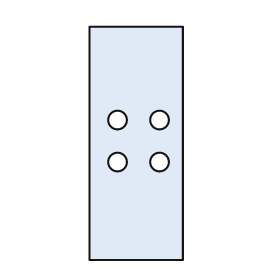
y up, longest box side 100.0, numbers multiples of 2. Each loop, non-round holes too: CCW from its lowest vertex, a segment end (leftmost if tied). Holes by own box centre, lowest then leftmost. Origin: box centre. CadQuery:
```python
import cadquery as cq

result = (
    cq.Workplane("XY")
    .moveTo(-20.0, -50.0)
    .lineTo(20.0, -50.0)
    .lineTo(20.0, 50.0)
    .lineTo(-20.0, 50.0)
    .close()
    .moveTo(-8.0, -8.0)
    .circle(4.0)
    .moveTo(10.0, -8.0)
    .circle(4.0)
    .moveTo(-8.0, 10.0)
    .circle(4.0)
    .moveTo(10.0, 10.0)
    .circle(4.0)
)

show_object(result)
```